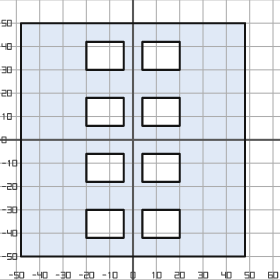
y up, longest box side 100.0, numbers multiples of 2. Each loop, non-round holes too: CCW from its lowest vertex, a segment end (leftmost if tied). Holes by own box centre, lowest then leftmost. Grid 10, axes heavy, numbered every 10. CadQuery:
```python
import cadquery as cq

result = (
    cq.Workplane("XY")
    .moveTo(-48.0, -50.0)
    .lineTo(48.0, -50.0)
    .lineTo(48.0, 50.0)
    .lineTo(-48.0, 50.0)
    .close()
    .moveTo(-20.0, -42.0)
    .lineTo(-4.0, -42.0)
    .lineTo(-4.0, -30.0)
    .lineTo(-20.0, -30.0)
    .close()
    .moveTo(4.0, -42.0)
    .lineTo(20.0, -42.0)
    .lineTo(20.0, -30.0)
    .lineTo(4.0, -30.0)
    .close()
    .moveTo(-20.0, -18.0)
    .lineTo(-4.0, -18.0)
    .lineTo(-4.0, -6.0)
    .lineTo(-20.0, -6.0)
    .close()
    .moveTo(4.0, -18.0)
    .lineTo(20.0, -18.0)
    .lineTo(20.0, -6.0)
    .lineTo(4.0, -6.0)
    .close()
    .moveTo(-20.0, 6.0)
    .lineTo(-4.0, 6.0)
    .lineTo(-4.0, 18.0)
    .lineTo(-20.0, 18.0)
    .close()
    .moveTo(4.0, 6.0)
    .lineTo(20.0, 6.0)
    .lineTo(20.0, 18.0)
    .lineTo(4.0, 18.0)
    .close()
    .moveTo(-20.0, 30.0)
    .lineTo(-4.0, 30.0)
    .lineTo(-4.0, 42.0)
    .lineTo(-20.0, 42.0)
    .close()
    .moveTo(4.0, 30.0)
    .lineTo(20.0, 30.0)
    .lineTo(20.0, 42.0)
    .lineTo(4.0, 42.0)
    .close()
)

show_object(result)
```